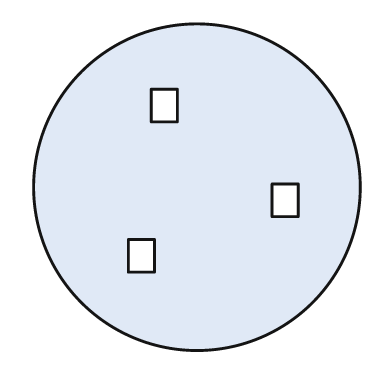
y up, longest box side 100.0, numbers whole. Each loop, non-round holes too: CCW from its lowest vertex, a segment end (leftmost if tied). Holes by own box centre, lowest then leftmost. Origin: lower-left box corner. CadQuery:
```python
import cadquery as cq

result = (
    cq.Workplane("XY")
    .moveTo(50.0, 50.0)
    .circle(50.0)
    .moveTo(29.0, 24.0)
    .lineTo(37.0, 24.0)
    .lineTo(37.0, 34.0)
    .lineTo(29.0, 34.0)
    .close()
    .moveTo(73.0, 41.0)
    .lineTo(81.0, 41.0)
    .lineTo(81.0, 51.0)
    .lineTo(73.0, 51.0)
    .close()
    .moveTo(36.0, 70.0)
    .lineTo(44.0, 70.0)
    .lineTo(44.0, 80.0)
    .lineTo(36.0, 80.0)
    .close()
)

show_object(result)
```